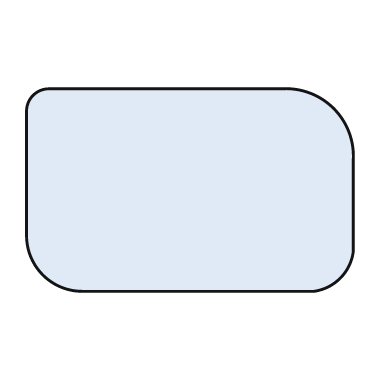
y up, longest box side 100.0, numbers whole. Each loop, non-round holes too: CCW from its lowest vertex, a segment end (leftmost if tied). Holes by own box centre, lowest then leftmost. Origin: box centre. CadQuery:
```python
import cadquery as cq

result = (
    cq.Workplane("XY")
    .moveTo(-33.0, -31.0)
    .lineTo(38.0, -31.0)
    .threePointArc((46.0, -27.0), (50.0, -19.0))
    .lineTo(50.0, 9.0)
    .threePointArc((44.0, 25.0), (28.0, 31.0))
    .lineTo(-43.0, 31.0)
    .threePointArc((-48.0, 29.0), (-50.0, 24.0))
    .lineTo(-50.0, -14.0)
    .threePointArc((-45.0, -26.0), (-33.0, -31.0))
    .close()
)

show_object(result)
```